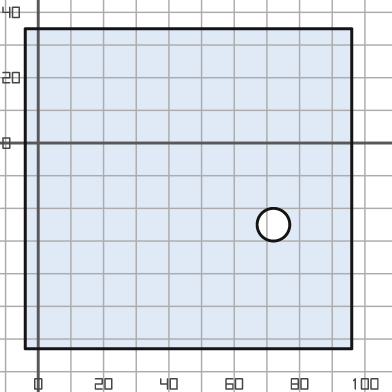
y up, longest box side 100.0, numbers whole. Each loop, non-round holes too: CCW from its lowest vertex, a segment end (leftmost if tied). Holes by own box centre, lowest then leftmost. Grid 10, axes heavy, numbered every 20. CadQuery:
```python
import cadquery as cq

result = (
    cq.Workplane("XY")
    .moveTo(-4.0, -63.0)
    .lineTo(96.0, -63.0)
    .lineTo(96.0, 35.0)
    .lineTo(-4.0, 35.0)
    .close()
    .moveTo(72.0, -25.0)
    .circle(5.0)
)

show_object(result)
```